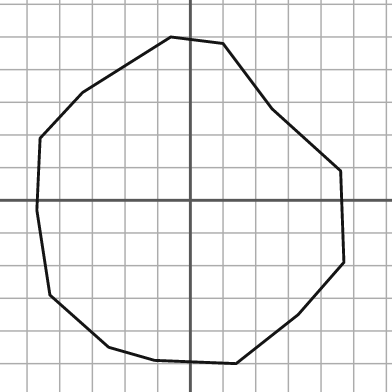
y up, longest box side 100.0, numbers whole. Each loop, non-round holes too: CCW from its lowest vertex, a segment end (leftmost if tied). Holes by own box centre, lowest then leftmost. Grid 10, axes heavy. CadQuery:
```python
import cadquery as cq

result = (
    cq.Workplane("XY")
    .moveTo(14.0, -50.0)
    .lineTo(33.0, -35.0)
    .lineTo(47.0, -19.0)
    .lineTo(46.0, 9.0)
    .lineTo(25.0, 28.0)
    .lineTo(10.0, 48.0)
    .lineTo(-6.0, 50.0)
    .lineTo(-33.0, 33.0)
    .lineTo(-46.0, 19.0)
    .lineTo(-47.0, -3.0)
    .lineTo(-43.0, -29.0)
    .lineTo(-25.0, -45.0)
    .lineTo(-11.0, -49.0)
    .close()
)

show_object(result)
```